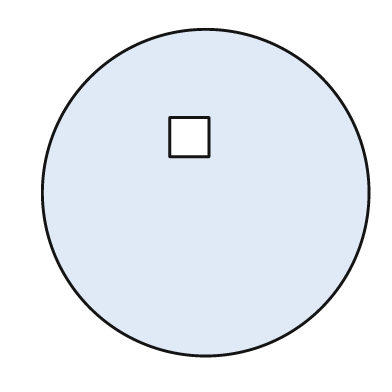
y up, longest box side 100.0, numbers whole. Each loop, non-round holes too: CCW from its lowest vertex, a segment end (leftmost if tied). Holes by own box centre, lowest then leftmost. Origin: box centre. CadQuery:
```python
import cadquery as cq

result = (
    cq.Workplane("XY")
    .moveTo(0.0, 0.0)
    .circle(50.0)
    .moveTo(-11.0, 11.0)
    .lineTo(1.0, 11.0)
    .lineTo(1.0, 23.0)
    .lineTo(-11.0, 23.0)
    .close()
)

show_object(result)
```